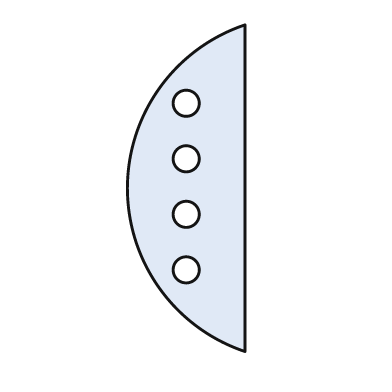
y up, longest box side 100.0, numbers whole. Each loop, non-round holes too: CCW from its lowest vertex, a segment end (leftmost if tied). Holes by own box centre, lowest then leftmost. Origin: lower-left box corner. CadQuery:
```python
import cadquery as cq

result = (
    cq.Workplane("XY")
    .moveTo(36.0, 0.0)
    .lineTo(36.0, 100.0)
    .threePointArc((0.0, 50.0), (36.0, 0.0))
    .close()
    .moveTo(18.0, 25.0)
    .circle(4.0)
    .moveTo(18.0, 42.0)
    .circle(4.0)
    .moveTo(18.0, 59.0)
    .circle(4.0)
    .moveTo(18.0, 76.0)
    .circle(4.0)
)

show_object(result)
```